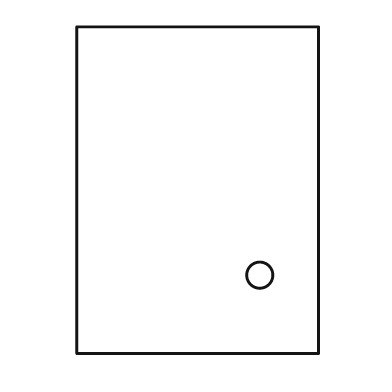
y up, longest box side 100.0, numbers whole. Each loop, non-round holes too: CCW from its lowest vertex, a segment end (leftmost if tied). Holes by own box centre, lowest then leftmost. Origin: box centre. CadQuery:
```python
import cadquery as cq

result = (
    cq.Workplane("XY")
    .moveTo(-37.0, -50.0)
    .lineTo(37.0, -50.0)
    .lineTo(37.0, 50.0)
    .lineTo(-37.0, 50.0)
    .close()
    .moveTo(19.0, -26.0)
    .circle(4.0)
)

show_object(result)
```